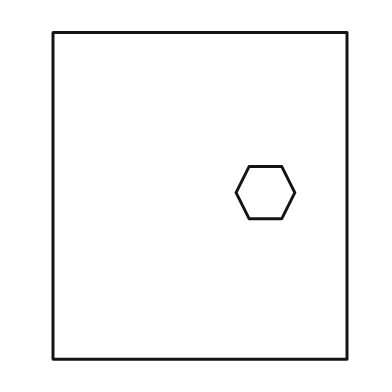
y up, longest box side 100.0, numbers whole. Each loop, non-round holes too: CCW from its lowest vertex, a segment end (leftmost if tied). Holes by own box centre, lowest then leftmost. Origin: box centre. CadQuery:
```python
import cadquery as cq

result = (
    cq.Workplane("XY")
    .moveTo(-45.0, -50.0)
    .lineTo(45.0, -50.0)
    .lineTo(45.0, 50.0)
    .lineTo(-45.0, 50.0)
    .close()
    .moveTo(15.0, -7.0)
    .lineTo(25.0, -7.0)
    .lineTo(29.0, 1.0)
    .lineTo(25.0, 9.0)
    .lineTo(15.0, 9.0)
    .lineTo(11.0, 1.0)
    .close()
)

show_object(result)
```